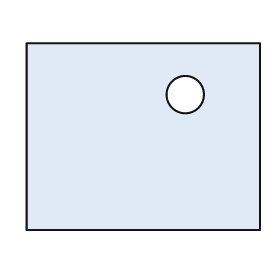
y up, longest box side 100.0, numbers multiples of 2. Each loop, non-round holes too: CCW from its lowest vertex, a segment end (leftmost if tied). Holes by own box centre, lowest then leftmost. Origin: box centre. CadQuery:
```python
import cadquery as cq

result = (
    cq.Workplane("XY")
    .moveTo(-50.0, -40.0)
    .lineTo(50.0, -40.0)
    .lineTo(50.0, 40.0)
    .lineTo(-50.0, 40.0)
    .close()
    .moveTo(18.0, 18.0)
    .circle(8.0)
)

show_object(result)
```